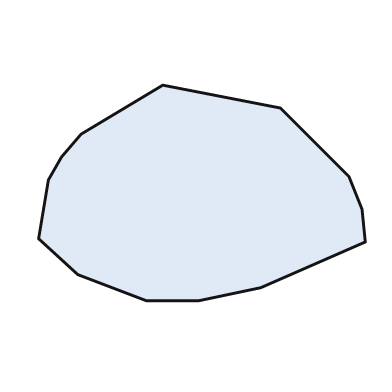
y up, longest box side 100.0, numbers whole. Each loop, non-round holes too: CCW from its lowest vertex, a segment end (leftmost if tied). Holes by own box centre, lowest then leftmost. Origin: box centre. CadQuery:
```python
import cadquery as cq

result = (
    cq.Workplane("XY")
    .moveTo(-17.0, -33.0)
    .lineTo(-1.0, -33.0)
    .lineTo(18.0, -29.0)
    .lineTo(50.0, -15.0)
    .lineTo(49.0, -5.0)
    .lineTo(45.0, 5.0)
    .lineTo(24.0, 26.0)
    .lineTo(-12.0, 33.0)
    .lineTo(-37.0, 18.0)
    .lineTo(-43.0, 11.0)
    .lineTo(-47.0, 4.0)
    .lineTo(-50.0, -14.0)
    .lineTo(-38.0, -25.0)
    .close()
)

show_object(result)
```